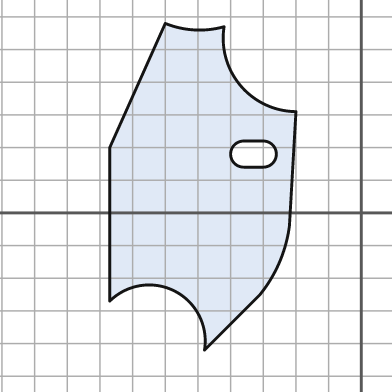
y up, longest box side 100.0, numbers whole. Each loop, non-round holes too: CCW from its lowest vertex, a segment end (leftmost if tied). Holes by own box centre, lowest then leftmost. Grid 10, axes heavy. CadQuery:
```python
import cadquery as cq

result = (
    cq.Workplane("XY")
    .moveTo(-48.0, -42.0)
    .lineTo(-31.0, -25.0)
    .threePointArc((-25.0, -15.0), (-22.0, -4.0))
    .lineTo(-20.0, 31.0)
    .threePointArc((-37.0, 39.0), (-42.0, 57.0))
    .threePointArc((-51.0, 56.0), (-60.0, 58.0))
    .lineTo(-77.0, 20.0)
    .lineTo(-77.0, -27.0)
    .threePointArc((-57.0, -24.0), (-48.0, -42.0))
    .close()
    .moveTo(-36.0, 14.0)
    .lineTo(-30.0, 14.0)
    .threePointArc((-26.0, 18.0), (-30.0, 22.0))
    .lineTo(-36.0, 22.0)
    .threePointArc((-40.0, 18.0), (-36.0, 14.0))
    .close()
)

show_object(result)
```